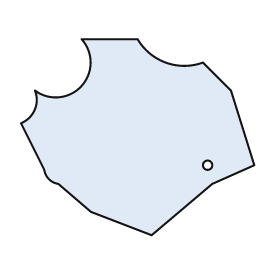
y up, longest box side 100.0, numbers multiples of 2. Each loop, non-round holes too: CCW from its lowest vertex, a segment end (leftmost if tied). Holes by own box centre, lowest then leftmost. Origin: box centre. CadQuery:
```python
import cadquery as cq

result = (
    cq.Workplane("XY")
    .moveTo(6.0, -42.0)
    .lineTo(32.0, -20.0)
    .lineTo(50.0, -12.0)
    .lineTo(40.0, 20.0)
    .lineTo(28.0, 32.0)
    .threePointArc((12.0, 32.0), (0.0, 42.0))
    .lineTo(-24.0, 42.0)
    .threePointArc((-24.0, 22.0), (-44.0, 20.0))
    .threePointArc((-44.0, 12.0), (-50.0, 6.0))
    .lineTo(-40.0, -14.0)
    .threePointArc((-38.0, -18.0), (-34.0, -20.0))
    .lineTo(-20.0, -32.0)
    .close()
    .moveTo(30.0, -12.0)
    .circle(2.0)
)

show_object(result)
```